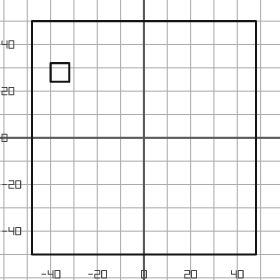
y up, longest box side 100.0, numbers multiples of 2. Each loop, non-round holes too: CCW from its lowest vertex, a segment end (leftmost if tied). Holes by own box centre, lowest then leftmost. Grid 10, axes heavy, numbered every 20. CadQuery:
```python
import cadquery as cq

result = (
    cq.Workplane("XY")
    .moveTo(-48.0, -50.0)
    .lineTo(48.0, -50.0)
    .lineTo(48.0, 50.0)
    .lineTo(-48.0, 50.0)
    .close()
    .moveTo(-40.0, 24.0)
    .lineTo(-32.0, 24.0)
    .lineTo(-32.0, 32.0)
    .lineTo(-40.0, 32.0)
    .close()
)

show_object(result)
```